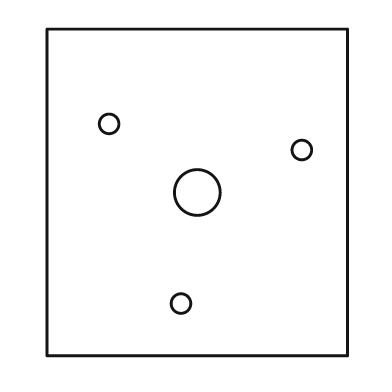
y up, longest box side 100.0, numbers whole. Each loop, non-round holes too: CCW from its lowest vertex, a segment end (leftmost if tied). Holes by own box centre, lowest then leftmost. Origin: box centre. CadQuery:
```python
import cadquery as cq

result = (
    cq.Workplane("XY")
    .moveTo(-46.0, -50.0)
    .lineTo(46.0, -50.0)
    .lineTo(46.0, 50.0)
    .lineTo(-46.0, 50.0)
    .close()
    .moveTo(-5.0, -34.0)
    .circle(3.0)
    .moveTo(0.0, 0.0)
    .circle(7.0)
    .moveTo(32.0, 13.0)
    .circle(3.0)
    .moveTo(-27.0, 21.0)
    .circle(3.0)
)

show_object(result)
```